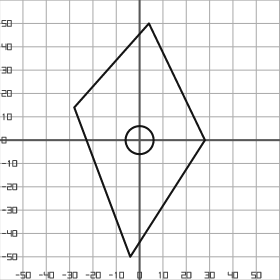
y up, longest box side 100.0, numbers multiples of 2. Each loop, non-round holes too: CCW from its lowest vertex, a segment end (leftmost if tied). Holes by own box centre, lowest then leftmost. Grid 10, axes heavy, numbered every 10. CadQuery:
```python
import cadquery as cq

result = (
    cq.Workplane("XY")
    .moveTo(-4.0, -50.0)
    .lineTo(28.0, 0.0)
    .lineTo(4.0, 50.0)
    .lineTo(-28.0, 14.0)
    .close()
    .moveTo(0.0, 0.0)
    .circle(6.0)
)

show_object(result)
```